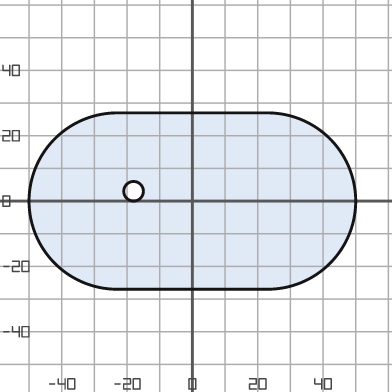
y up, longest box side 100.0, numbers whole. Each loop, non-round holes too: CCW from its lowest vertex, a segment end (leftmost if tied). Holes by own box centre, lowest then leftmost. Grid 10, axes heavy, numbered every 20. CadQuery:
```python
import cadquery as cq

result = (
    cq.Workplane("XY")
    .moveTo(-23.0, -27.0)
    .lineTo(23.0, -27.0)
    .threePointArc((50.0, 0.0), (23.0, 27.0))
    .lineTo(-23.0, 27.0)
    .threePointArc((-50.0, 0.0), (-23.0, -27.0))
    .close()
    .moveTo(-18.0, 3.0)
    .circle(3.0)
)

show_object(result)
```